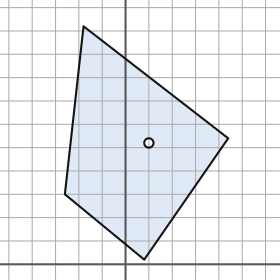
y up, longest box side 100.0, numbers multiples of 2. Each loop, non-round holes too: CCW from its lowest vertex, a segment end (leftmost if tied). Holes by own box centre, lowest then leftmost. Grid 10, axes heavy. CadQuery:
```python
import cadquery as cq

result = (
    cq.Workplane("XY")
    .moveTo(8.0, 2.0)
    .lineTo(44.0, 54.0)
    .lineTo(-18.0, 102.0)
    .lineTo(-26.0, 30.0)
    .close()
    .moveTo(10.0, 52.0)
    .circle(2.0)
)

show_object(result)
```